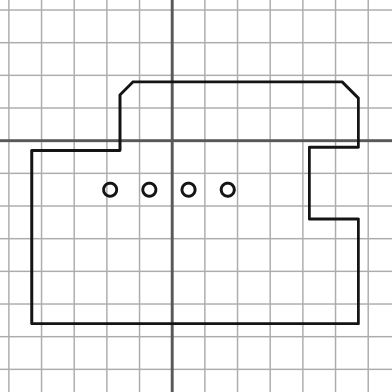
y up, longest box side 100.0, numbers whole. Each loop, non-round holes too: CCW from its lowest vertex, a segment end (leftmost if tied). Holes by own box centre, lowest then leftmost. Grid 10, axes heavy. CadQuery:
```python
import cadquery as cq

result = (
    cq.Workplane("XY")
    .moveTo(-43.0, -56.0)
    .lineTo(57.0, -56.0)
    .lineTo(57.0, -24.0)
    .lineTo(42.0, -24.0)
    .lineTo(42.0, -2.0)
    .lineTo(57.0, -2.0)
    .lineTo(57.0, 13.0)
    .lineTo(52.0, 18.0)
    .lineTo(-12.0, 18.0)
    .lineTo(-16.0, 14.0)
    .lineTo(-16.0, -3.0)
    .lineTo(-43.0, -3.0)
    .close()
    .moveTo(-19.0, -15.0)
    .circle(2.0)
    .moveTo(-7.0, -15.0)
    .circle(2.0)
    .moveTo(5.0, -15.0)
    .circle(2.0)
    .moveTo(17.0, -15.0)
    .circle(2.0)
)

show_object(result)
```